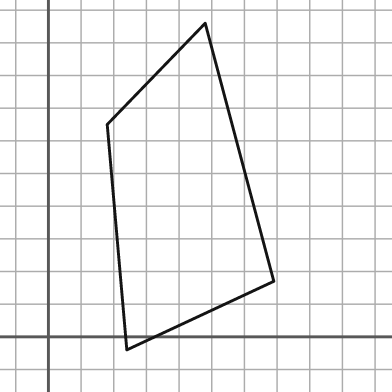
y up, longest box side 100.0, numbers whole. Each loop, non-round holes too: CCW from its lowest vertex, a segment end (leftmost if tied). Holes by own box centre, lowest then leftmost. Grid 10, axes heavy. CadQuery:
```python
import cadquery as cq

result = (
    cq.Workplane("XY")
    .moveTo(24.0, -4.0)
    .lineTo(69.0, 17.0)
    .lineTo(48.0, 96.0)
    .lineTo(18.0, 65.0)
    .close()
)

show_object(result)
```